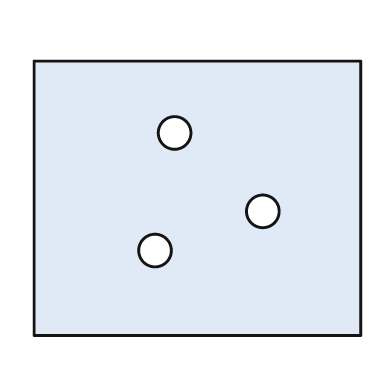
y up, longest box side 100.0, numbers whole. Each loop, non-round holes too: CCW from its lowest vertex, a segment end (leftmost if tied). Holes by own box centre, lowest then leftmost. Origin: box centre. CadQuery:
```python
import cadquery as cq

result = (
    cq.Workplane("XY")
    .moveTo(-50.0, -42.0)
    .lineTo(50.0, -42.0)
    .lineTo(50.0, 42.0)
    .lineTo(-50.0, 42.0)
    .close()
    .moveTo(-13.0, -16.0)
    .circle(5.0)
    .moveTo(20.0, -4.0)
    .circle(5.0)
    .moveTo(-7.0, 20.0)
    .circle(5.0)
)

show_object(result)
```